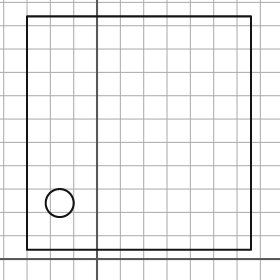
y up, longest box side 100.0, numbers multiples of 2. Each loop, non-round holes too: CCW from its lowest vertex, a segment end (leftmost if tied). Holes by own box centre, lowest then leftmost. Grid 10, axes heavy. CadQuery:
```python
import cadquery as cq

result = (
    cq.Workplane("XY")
    .moveTo(-30.0, 4.0)
    .lineTo(66.0, 4.0)
    .lineTo(66.0, 104.0)
    .lineTo(-30.0, 104.0)
    .close()
    .moveTo(-16.0, 24.0)
    .circle(6.0)
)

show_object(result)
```